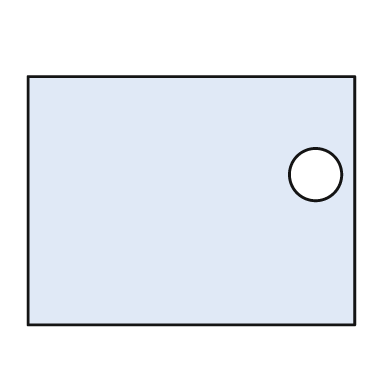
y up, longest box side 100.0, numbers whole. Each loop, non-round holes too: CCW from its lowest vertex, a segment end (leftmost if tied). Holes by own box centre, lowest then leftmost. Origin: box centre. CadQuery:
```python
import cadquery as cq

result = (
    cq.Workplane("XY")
    .moveTo(-50.0, -38.0)
    .lineTo(50.0, -38.0)
    .lineTo(50.0, 38.0)
    .lineTo(-50.0, 38.0)
    .close()
    .moveTo(38.0, 8.0)
    .circle(8.0)
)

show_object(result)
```